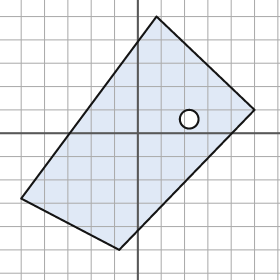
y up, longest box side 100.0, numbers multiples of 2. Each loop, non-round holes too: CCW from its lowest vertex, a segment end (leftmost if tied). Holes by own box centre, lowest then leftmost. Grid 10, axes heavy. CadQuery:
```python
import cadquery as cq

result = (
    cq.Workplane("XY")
    .moveTo(-8.0, -50.0)
    .lineTo(50.0, 10.0)
    .lineTo(8.0, 50.0)
    .lineTo(-50.0, -28.0)
    .close()
    .moveTo(22.0, 6.0)
    .circle(4.0)
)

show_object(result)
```